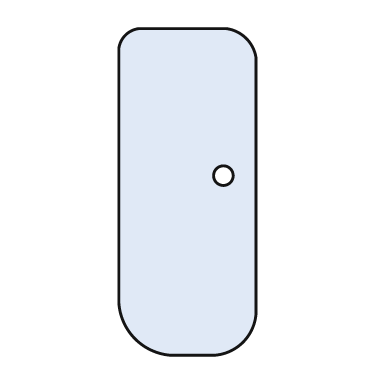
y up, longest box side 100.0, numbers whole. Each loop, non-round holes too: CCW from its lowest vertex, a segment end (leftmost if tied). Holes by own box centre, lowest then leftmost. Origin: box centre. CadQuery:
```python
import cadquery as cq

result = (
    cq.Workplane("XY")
    .moveTo(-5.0, -50.0)
    .lineTo(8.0, -50.0)
    .threePointArc((17.0, -46.0), (21.0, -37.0))
    .lineTo(21.0, 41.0)
    .threePointArc((18.0, 47.0), (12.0, 50.0))
    .lineTo(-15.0, 50.0)
    .threePointArc((-19.0, 48.0), (-21.0, 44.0))
    .lineTo(-21.0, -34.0)
    .threePointArc((-16.0, -45.0), (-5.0, -50.0))
    .close()
    .moveTo(11.0, 5.0)
    .circle(3.0)
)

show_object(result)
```